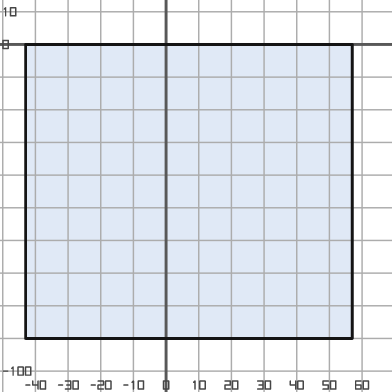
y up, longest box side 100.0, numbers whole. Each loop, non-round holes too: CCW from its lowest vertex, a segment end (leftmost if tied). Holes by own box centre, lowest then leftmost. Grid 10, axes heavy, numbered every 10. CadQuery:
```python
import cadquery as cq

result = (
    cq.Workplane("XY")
    .moveTo(-43.0, -90.0)
    .lineTo(57.0, -90.0)
    .lineTo(57.0, 0.0)
    .lineTo(-43.0, 0.0)
    .close()
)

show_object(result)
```